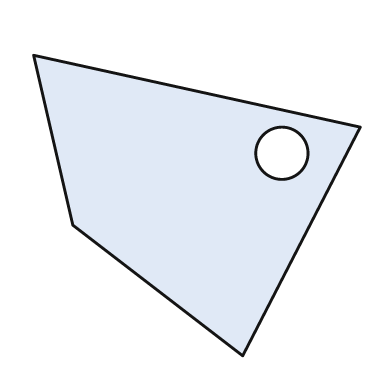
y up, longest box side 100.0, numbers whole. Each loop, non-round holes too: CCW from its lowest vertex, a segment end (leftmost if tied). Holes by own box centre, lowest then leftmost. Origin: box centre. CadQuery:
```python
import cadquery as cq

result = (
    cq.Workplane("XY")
    .moveTo(14.0, -46.0)
    .lineTo(50.0, 24.0)
    .lineTo(-50.0, 46.0)
    .lineTo(-38.0, -6.0)
    .close()
    .moveTo(26.0, 16.0)
    .circle(8.0)
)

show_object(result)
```